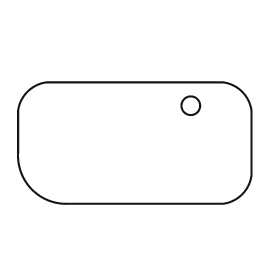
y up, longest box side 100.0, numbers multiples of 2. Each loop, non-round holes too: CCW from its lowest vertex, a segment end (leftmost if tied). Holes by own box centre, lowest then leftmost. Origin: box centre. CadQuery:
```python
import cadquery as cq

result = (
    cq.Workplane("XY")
    .moveTo(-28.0, -26.0)
    .lineTo(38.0, -26.0)
    .threePointArc((46.0, -22.0), (50.0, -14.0))
    .lineTo(50.0, 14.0)
    .threePointArc((46.0, 22.0), (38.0, 26.0))
    .lineTo(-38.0, 26.0)
    .threePointArc((-46.0, 22.0), (-50.0, 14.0))
    .lineTo(-50.0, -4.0)
    .threePointArc((-44.0, -20.0), (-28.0, -26.0))
    .close()
    .moveTo(24.0, 16.0)
    .circle(4.0)
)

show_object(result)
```